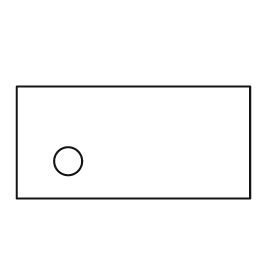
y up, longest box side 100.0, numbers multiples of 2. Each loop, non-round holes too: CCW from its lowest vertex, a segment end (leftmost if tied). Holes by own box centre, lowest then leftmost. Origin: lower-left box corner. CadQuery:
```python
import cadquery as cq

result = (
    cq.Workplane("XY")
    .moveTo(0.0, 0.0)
    .lineTo(100.0, 0.0)
    .lineTo(100.0, 48.0)
    .lineTo(0.0, 48.0)
    .close()
    .moveTo(22.0, 16.0)
    .circle(6.0)
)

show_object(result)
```